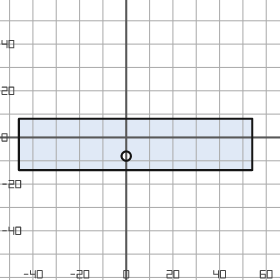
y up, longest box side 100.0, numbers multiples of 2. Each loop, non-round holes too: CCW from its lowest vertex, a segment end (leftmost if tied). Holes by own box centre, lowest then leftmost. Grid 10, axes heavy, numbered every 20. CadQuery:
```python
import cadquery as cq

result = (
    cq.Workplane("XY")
    .moveTo(-46.0, -14.0)
    .lineTo(54.0, -14.0)
    .lineTo(54.0, 8.0)
    .lineTo(-46.0, 8.0)
    .close()
    .moveTo(0.0, -8.0)
    .circle(2.0)
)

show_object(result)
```